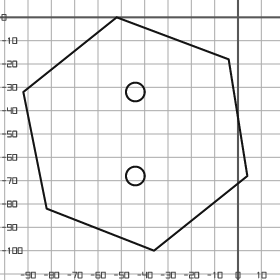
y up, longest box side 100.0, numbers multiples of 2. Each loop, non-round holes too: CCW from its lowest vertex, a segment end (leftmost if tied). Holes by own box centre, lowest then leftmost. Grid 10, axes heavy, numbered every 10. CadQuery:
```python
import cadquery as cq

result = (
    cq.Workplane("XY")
    .moveTo(-36.0, -100.0)
    .lineTo(4.0, -68.0)
    .lineTo(-4.0, -18.0)
    .lineTo(-52.0, 0.0)
    .lineTo(-92.0, -32.0)
    .lineTo(-82.0, -82.0)
    .close()
    .moveTo(-44.0, -68.0)
    .circle(4.0)
    .moveTo(-44.0, -32.0)
    .circle(4.0)
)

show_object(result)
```